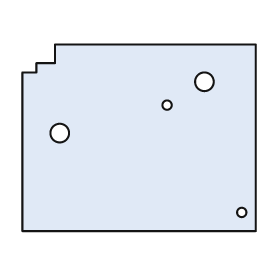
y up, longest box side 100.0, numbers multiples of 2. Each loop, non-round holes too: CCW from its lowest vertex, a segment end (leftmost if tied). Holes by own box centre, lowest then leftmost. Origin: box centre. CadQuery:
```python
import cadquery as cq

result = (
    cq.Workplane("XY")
    .moveTo(-50.0, -40.0)
    .lineTo(50.0, -40.0)
    .lineTo(50.0, 40.0)
    .lineTo(-36.0, 40.0)
    .lineTo(-36.0, 32.0)
    .lineTo(-44.0, 32.0)
    .lineTo(-44.0, 28.0)
    .lineTo(-50.0, 28.0)
    .close()
    .moveTo(44.0, -32.0)
    .circle(2.0)
    .moveTo(-34.0, 2.0)
    .circle(4.0)
    .moveTo(12.0, 14.0)
    .circle(2.0)
    .moveTo(28.0, 24.0)
    .circle(4.0)
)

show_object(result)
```